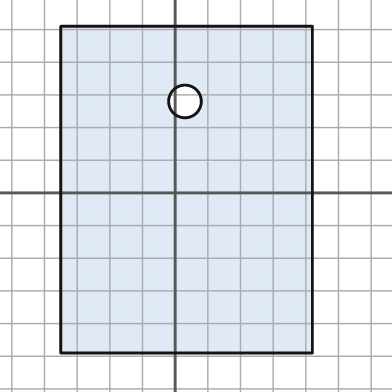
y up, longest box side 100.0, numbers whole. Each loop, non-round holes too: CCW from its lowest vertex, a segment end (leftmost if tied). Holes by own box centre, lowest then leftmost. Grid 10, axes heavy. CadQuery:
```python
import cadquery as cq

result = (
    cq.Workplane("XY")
    .moveTo(-35.0, -49.0)
    .lineTo(42.0, -49.0)
    .lineTo(42.0, 51.0)
    .lineTo(-35.0, 51.0)
    .close()
    .moveTo(3.0, 28.0)
    .circle(5.0)
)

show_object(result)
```